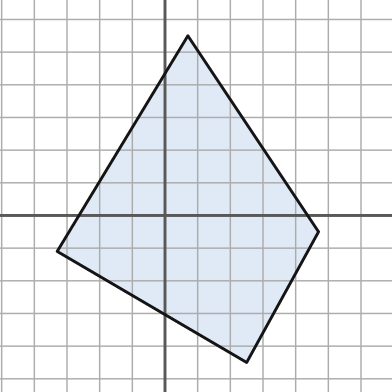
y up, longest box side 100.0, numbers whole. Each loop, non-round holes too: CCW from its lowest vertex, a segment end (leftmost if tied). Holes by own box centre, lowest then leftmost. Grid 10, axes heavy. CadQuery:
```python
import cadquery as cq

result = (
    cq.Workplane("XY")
    .moveTo(25.0, -45.0)
    .lineTo(47.0, -5.0)
    .lineTo(7.0, 55.0)
    .lineTo(-33.0, -11.0)
    .close()
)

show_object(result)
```